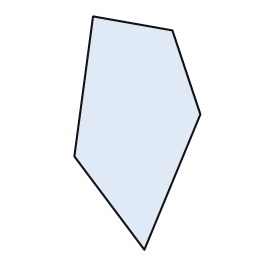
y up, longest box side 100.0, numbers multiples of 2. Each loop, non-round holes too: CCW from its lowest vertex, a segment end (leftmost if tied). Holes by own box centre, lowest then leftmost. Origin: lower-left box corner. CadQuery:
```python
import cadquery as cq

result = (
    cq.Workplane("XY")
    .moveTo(30.0, 0.0)
    .lineTo(54.0, 58.0)
    .lineTo(42.0, 94.0)
    .lineTo(8.0, 100.0)
    .lineTo(0.0, 40.0)
    .close()
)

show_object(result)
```